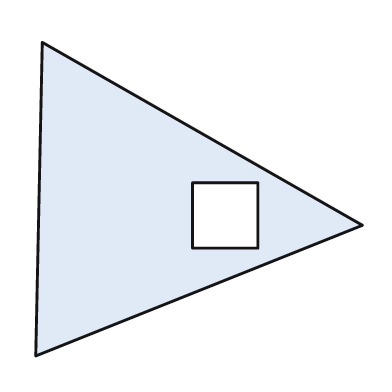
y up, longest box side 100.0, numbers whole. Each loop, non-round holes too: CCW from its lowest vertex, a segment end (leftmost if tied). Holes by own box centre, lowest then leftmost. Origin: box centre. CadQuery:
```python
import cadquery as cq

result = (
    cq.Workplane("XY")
    .moveTo(-50.0, -48.0)
    .lineTo(50.0, -8.0)
    .lineTo(-48.0, 48.0)
    .close()
    .moveTo(-2.0, -15.0)
    .lineTo(18.0, -15.0)
    .lineTo(18.0, 5.0)
    .lineTo(-2.0, 5.0)
    .close()
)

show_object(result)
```